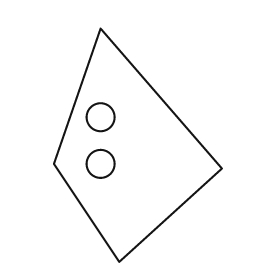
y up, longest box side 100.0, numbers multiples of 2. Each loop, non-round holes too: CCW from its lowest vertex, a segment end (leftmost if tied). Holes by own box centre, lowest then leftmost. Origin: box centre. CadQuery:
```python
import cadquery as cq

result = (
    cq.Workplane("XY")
    .moveTo(-8.0, -50.0)
    .lineTo(36.0, -10.0)
    .lineTo(-16.0, 50.0)
    .lineTo(-36.0, -8.0)
    .close()
    .moveTo(-16.0, -8.0)
    .circle(6.0)
    .moveTo(-16.0, 12.0)
    .circle(6.0)
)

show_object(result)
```